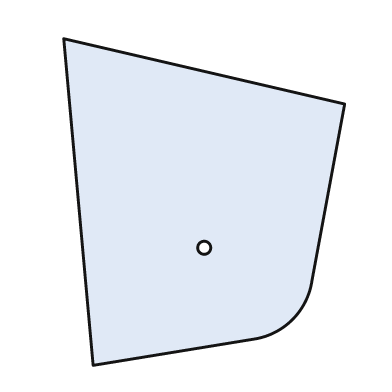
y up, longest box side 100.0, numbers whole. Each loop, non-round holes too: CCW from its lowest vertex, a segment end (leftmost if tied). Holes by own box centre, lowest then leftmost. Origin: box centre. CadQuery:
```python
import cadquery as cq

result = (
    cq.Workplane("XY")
    .moveTo(-34.0, -50.0)
    .lineTo(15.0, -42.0)
    .threePointArc((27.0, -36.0), (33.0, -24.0))
    .lineTo(43.0, 30.0)
    .lineTo(-43.0, 50.0)
    .close()
    .moveTo(0.0, -14.0)
    .circle(2.0)
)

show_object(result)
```